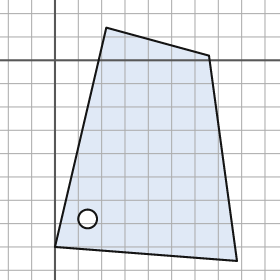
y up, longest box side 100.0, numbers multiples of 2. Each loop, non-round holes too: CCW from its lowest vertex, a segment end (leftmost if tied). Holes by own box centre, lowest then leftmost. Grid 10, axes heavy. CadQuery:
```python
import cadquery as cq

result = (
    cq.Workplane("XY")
    .moveTo(78.0, -86.0)
    .lineTo(66.0, 2.0)
    .lineTo(22.0, 14.0)
    .lineTo(0.0, -80.0)
    .close()
    .moveTo(14.0, -68.0)
    .circle(4.0)
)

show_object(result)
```